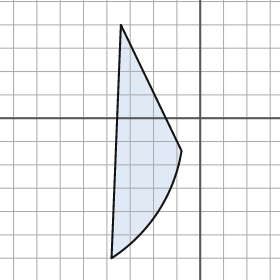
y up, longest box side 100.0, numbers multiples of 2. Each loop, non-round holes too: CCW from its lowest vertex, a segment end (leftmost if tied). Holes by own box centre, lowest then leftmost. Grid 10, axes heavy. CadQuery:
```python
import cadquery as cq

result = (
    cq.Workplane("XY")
    .moveTo(-38.0, -60.0)
    .threePointArc((-18.0, -40.0), (-8.0, -14.0))
    .lineTo(-34.0, 40.0)
    .close()
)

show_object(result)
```